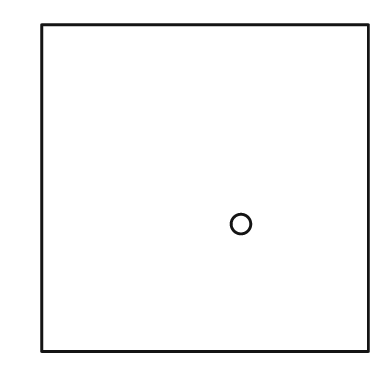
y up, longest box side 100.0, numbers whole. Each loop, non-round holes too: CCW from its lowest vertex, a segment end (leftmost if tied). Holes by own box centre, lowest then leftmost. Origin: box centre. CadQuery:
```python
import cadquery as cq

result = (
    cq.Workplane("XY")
    .moveTo(-50.0, -50.0)
    .lineTo(50.0, -50.0)
    .lineTo(50.0, 50.0)
    .lineTo(-50.0, 50.0)
    .close()
    .moveTo(11.0, -11.0)
    .circle(3.0)
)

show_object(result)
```